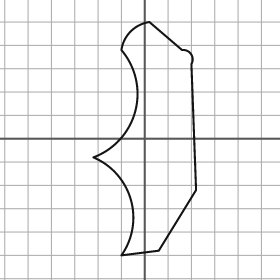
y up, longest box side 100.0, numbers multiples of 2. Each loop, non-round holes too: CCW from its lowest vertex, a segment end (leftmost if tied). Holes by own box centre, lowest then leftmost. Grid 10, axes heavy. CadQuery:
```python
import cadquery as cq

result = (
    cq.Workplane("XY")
    .moveTo(-10.0, -50.0)
    .lineTo(6.0, -48.0)
    .lineTo(22.0, -22.0)
    .lineTo(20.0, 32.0)
    .threePointArc((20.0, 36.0), (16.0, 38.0))
    .lineTo(2.0, 50.0)
    .threePointArc((-6.0, 46.0), (-10.0, 38.0))
    .threePointArc((-4.0, 12.0), (-22.0, -8.0))
    .threePointArc((-6.0, -26.0), (-10.0, -50.0))
    .close()
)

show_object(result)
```